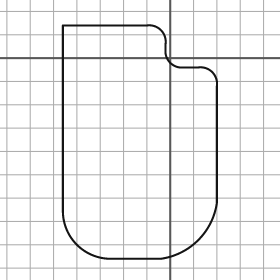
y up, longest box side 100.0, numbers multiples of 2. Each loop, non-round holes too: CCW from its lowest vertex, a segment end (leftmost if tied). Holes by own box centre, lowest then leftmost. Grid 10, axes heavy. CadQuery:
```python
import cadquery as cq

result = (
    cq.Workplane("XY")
    .moveTo(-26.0, -86.0)
    .lineTo(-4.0, -86.0)
    .threePointArc((12.0, -78.0), (20.0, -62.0))
    .lineTo(20.0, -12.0)
    .threePointArc((18.0, -6.0), (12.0, -4.0))
    .lineTo(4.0, -4.0)
    .threePointArc((0.0, -2.0), (-2.0, 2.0))
    .lineTo(-2.0, 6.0)
    .threePointArc((-4.0, 12.0), (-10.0, 14.0))
    .lineTo(-46.0, 14.0)
    .lineTo(-46.0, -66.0)
    .threePointArc((-40.0, -80.0), (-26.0, -86.0))
    .close()
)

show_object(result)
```